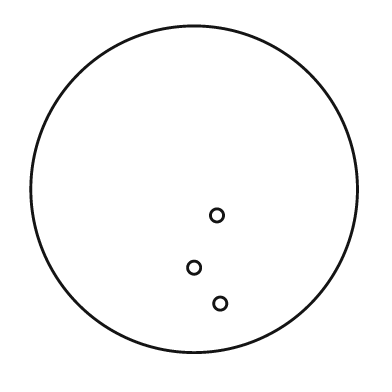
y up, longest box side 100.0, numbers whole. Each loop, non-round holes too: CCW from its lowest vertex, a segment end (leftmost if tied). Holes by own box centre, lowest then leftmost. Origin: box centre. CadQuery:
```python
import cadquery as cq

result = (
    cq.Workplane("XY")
    .moveTo(0.0, 0.0)
    .circle(50.0)
    .moveTo(8.0, -35.0)
    .circle(2.0)
    .moveTo(0.0, -24.0)
    .circle(2.0)
    .moveTo(7.0, -8.0)
    .circle(2.0)
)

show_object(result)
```